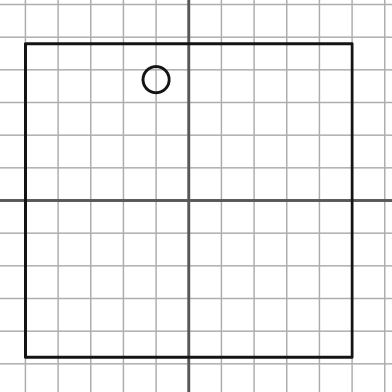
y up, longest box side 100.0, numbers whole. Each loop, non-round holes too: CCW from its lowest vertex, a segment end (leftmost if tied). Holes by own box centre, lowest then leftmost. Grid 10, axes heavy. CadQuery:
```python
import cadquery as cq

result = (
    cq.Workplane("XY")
    .moveTo(-50.0, -48.0)
    .lineTo(50.0, -48.0)
    .lineTo(50.0, 48.0)
    .lineTo(-50.0, 48.0)
    .close()
    .moveTo(-10.0, 37.0)
    .circle(4.0)
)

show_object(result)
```